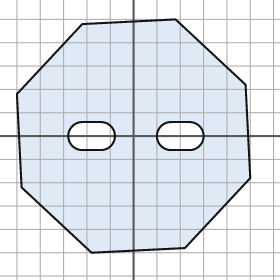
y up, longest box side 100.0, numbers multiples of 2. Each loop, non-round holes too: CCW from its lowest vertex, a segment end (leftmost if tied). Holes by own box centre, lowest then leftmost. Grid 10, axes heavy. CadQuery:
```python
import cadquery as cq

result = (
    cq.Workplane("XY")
    .moveTo(-18.0, -50.0)
    .lineTo(22.0, -48.0)
    .lineTo(50.0, -18.0)
    .lineTo(48.0, 22.0)
    .lineTo(18.0, 50.0)
    .lineTo(-22.0, 48.0)
    .lineTo(-50.0, 18.0)
    .lineTo(-48.0, -22.0)
    .close()
    .moveTo(-22.0, -6.0)
    .lineTo(-14.0, -6.0)
    .threePointArc((-8.0, 0.0), (-14.0, 6.0))
    .lineTo(-22.0, 6.0)
    .threePointArc((-28.0, 0.0), (-22.0, -6.0))
    .close()
    .moveTo(16.0, -6.0)
    .lineTo(24.0, -6.0)
    .threePointArc((30.0, 0.0), (24.0, 6.0))
    .lineTo(16.0, 6.0)
    .threePointArc((10.0, 0.0), (16.0, -6.0))
    .close()
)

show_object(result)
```